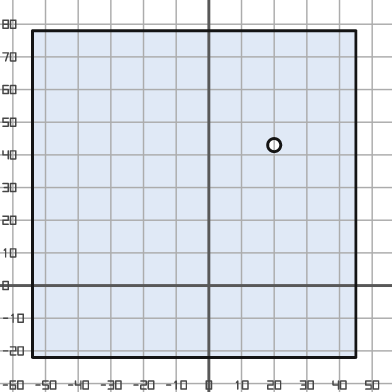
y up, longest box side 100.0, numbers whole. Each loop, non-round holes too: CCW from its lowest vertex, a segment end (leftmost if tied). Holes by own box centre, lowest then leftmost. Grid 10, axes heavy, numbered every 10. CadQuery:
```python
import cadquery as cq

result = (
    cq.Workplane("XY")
    .moveTo(-54.0, -22.0)
    .lineTo(45.0, -22.0)
    .lineTo(45.0, 78.0)
    .lineTo(-54.0, 78.0)
    .close()
    .moveTo(20.0, 43.0)
    .circle(2.0)
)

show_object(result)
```